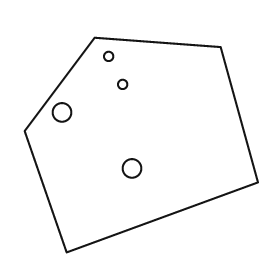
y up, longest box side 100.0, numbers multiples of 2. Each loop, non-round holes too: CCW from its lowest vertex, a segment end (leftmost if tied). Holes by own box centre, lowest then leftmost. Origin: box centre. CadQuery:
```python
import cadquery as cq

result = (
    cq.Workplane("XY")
    .moveTo(-32.0, -46.0)
    .lineTo(50.0, -16.0)
    .lineTo(34.0, 42.0)
    .lineTo(-20.0, 46.0)
    .lineTo(-50.0, 6.0)
    .close()
    .moveTo(-4.0, -10.0)
    .circle(4.0)
    .moveTo(-34.0, 14.0)
    .circle(4.0)
    .moveTo(-8.0, 26.0)
    .circle(2.0)
    .moveTo(-14.0, 38.0)
    .circle(2.0)
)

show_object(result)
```